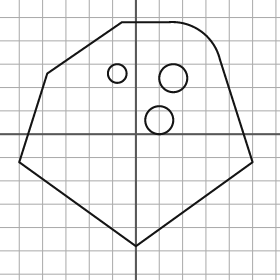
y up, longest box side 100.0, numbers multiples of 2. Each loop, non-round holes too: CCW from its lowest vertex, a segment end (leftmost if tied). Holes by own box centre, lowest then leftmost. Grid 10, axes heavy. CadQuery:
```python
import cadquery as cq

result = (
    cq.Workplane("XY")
    .moveTo(0.0, -48.0)
    .lineTo(50.0, -12.0)
    .lineTo(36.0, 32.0)
    .threePointArc((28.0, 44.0), (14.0, 48.0))
    .lineTo(-6.0, 48.0)
    .lineTo(-38.0, 26.0)
    .lineTo(-50.0, -12.0)
    .close()
    .moveTo(10.0, 6.0)
    .circle(6.0)
    .moveTo(16.0, 24.0)
    .circle(6.0)
    .moveTo(-8.0, 26.0)
    .circle(4.0)
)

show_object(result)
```